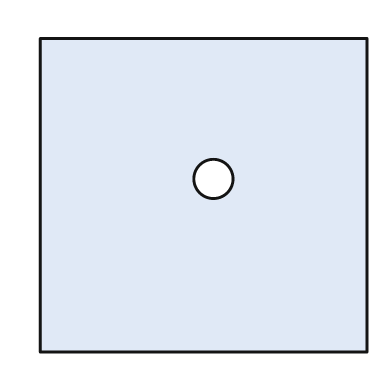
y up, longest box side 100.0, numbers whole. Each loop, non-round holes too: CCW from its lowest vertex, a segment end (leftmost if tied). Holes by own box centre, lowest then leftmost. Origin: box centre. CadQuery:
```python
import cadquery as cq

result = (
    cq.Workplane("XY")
    .moveTo(-50.0, -48.0)
    .lineTo(50.0, -48.0)
    .lineTo(50.0, 48.0)
    .lineTo(-50.0, 48.0)
    .close()
    .moveTo(3.0, 5.0)
    .circle(6.0)
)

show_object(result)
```